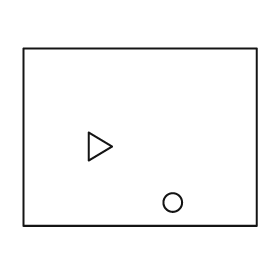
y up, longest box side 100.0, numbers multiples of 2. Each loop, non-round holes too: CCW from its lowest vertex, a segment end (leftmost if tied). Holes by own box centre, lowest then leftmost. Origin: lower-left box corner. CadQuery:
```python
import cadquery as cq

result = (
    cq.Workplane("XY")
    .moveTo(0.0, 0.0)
    .lineTo(100.0, 0.0)
    .lineTo(100.0, 76.0)
    .lineTo(0.0, 76.0)
    .close()
    .moveTo(64.0, 10.0)
    .circle(4.0)
    .moveTo(28.0, 28.0)
    .lineTo(38.0, 34.0)
    .lineTo(28.0, 40.0)
    .close()
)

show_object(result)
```